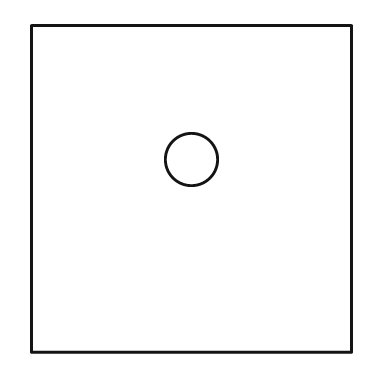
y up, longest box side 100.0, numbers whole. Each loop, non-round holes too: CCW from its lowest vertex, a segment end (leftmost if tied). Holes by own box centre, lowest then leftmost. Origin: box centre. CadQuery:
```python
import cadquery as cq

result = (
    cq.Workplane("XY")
    .moveTo(-49.0, -50.0)
    .lineTo(49.0, -50.0)
    .lineTo(49.0, 50.0)
    .lineTo(-49.0, 50.0)
    .close()
    .moveTo(0.0, 9.0)
    .circle(8.0)
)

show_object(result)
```